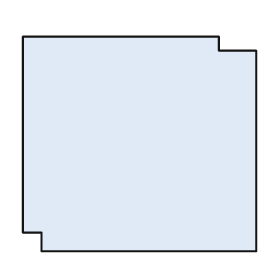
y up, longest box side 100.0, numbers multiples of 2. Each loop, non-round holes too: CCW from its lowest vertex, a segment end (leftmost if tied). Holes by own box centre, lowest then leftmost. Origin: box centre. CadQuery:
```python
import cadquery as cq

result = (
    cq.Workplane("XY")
    .moveTo(-42.0, -46.0)
    .lineTo(50.0, -46.0)
    .lineTo(50.0, 40.0)
    .lineTo(34.0, 40.0)
    .lineTo(34.0, 46.0)
    .lineTo(-50.0, 46.0)
    .lineTo(-50.0, -38.0)
    .lineTo(-42.0, -38.0)
    .close()
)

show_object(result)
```